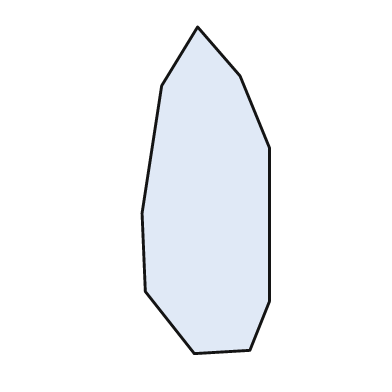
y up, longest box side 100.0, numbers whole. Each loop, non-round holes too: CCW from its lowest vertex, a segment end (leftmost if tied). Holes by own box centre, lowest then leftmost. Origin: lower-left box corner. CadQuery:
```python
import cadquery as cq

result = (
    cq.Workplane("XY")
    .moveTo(16.0, 0.0)
    .lineTo(33.0, 1.0)
    .lineTo(39.0, 16.0)
    .lineTo(39.0, 63.0)
    .lineTo(30.0, 85.0)
    .lineTo(17.0, 100.0)
    .lineTo(6.0, 82.0)
    .lineTo(0.0, 43.0)
    .lineTo(1.0, 19.0)
    .close()
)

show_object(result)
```